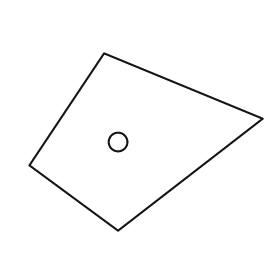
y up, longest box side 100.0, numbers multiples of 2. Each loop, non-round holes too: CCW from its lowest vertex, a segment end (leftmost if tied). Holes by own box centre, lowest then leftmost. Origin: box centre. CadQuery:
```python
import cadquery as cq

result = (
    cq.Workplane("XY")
    .moveTo(-12.0, -38.0)
    .lineTo(50.0, 10.0)
    .lineTo(-18.0, 38.0)
    .lineTo(-50.0, -10.0)
    .close()
    .moveTo(-12.0, 0.0)
    .circle(4.0)
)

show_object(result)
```